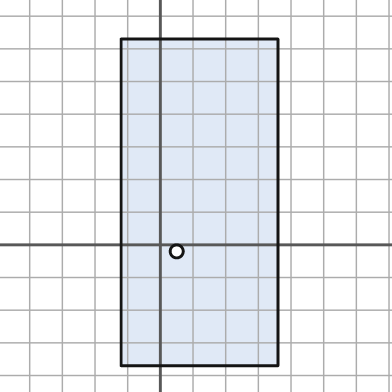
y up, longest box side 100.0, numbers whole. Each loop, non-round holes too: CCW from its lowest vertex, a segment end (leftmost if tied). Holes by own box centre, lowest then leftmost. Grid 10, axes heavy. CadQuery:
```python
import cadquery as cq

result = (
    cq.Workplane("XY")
    .moveTo(-12.0, -37.0)
    .lineTo(36.0, -37.0)
    .lineTo(36.0, 63.0)
    .lineTo(-12.0, 63.0)
    .close()
    .moveTo(5.0, -2.0)
    .circle(2.0)
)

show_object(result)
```